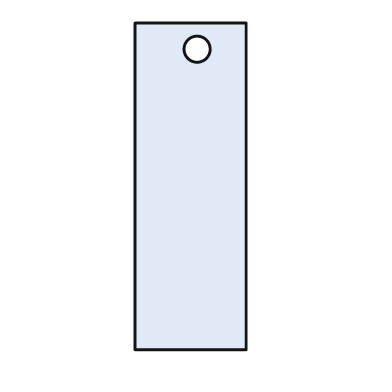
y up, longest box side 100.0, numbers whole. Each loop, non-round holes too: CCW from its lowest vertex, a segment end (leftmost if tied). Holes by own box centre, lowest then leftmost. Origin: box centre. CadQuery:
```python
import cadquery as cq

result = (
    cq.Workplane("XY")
    .moveTo(-17.0, -50.0)
    .lineTo(17.0, -50.0)
    .lineTo(17.0, 50.0)
    .lineTo(-17.0, 50.0)
    .close()
    .moveTo(2.0, 42.0)
    .circle(4.0)
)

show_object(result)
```